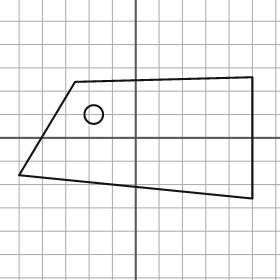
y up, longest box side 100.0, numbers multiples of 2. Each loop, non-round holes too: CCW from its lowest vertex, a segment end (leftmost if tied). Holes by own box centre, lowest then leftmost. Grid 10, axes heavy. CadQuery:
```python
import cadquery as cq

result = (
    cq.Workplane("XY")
    .moveTo(50.0, -26.0)
    .lineTo(50.0, 26.0)
    .lineTo(-26.0, 24.0)
    .lineTo(-50.0, -16.0)
    .close()
    .moveTo(-18.0, 10.0)
    .circle(4.0)
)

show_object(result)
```